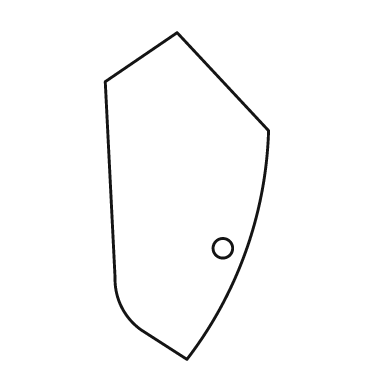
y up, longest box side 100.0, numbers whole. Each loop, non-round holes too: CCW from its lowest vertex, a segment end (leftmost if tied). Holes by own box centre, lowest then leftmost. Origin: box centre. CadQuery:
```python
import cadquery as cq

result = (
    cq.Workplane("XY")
    .moveTo(0.0, -50.0)
    .threePointArc((18.0, -17.0), (25.0, 20.0))
    .lineTo(-3.0, 50.0)
    .lineTo(-25.0, 35.0)
    .lineTo(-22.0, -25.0)
    .threePointArc((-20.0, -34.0), (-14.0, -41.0))
    .close()
    .moveTo(11.0, -16.0)
    .circle(3.0)
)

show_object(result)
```